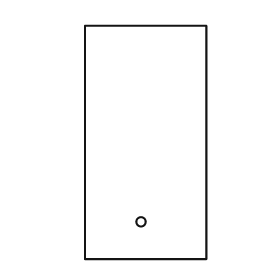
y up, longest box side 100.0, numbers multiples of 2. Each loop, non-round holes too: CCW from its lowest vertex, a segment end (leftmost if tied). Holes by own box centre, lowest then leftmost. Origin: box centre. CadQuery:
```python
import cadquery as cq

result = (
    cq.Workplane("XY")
    .moveTo(-26.0, -50.0)
    .lineTo(26.0, -50.0)
    .lineTo(26.0, 50.0)
    .lineTo(-26.0, 50.0)
    .close()
    .moveTo(-2.0, -34.0)
    .circle(2.0)
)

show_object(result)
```